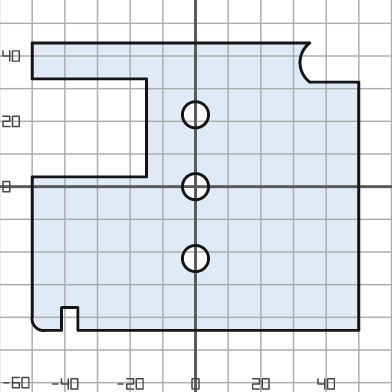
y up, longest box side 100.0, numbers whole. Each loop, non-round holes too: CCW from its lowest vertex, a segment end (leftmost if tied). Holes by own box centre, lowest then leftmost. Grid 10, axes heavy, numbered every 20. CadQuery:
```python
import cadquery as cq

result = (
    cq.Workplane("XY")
    .moveTo(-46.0, -44.0)
    .lineTo(-41.0, -44.0)
    .lineTo(-41.0, -37.0)
    .lineTo(-36.0, -37.0)
    .lineTo(-36.0, -44.0)
    .lineTo(50.0, -44.0)
    .lineTo(50.0, 32.0)
    .lineTo(35.0, 32.0)
    .threePointArc((32.0, 38.0), (35.0, 44.0))
    .lineTo(-50.0, 44.0)
    .lineTo(-50.0, 33.0)
    .lineTo(-15.0, 33.0)
    .lineTo(-15.0, 3.0)
    .lineTo(-50.0, 3.0)
    .lineTo(-50.0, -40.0)
    .threePointArc((-49.0, -43.0), (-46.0, -44.0))
    .close()
    .moveTo(0.0, -22.0)
    .circle(4.0)
    .moveTo(0.0, 0.0)
    .circle(4.0)
    .moveTo(0.0, 22.0)
    .circle(4.0)
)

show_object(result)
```